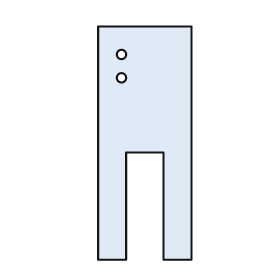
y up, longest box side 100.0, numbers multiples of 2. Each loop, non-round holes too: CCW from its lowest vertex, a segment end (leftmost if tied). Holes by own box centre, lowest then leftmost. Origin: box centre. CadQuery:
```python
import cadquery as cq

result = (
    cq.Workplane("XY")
    .moveTo(-20.0, -50.0)
    .lineTo(-8.0, -50.0)
    .lineTo(-8.0, -4.0)
    .lineTo(8.0, -4.0)
    .lineTo(8.0, -50.0)
    .lineTo(20.0, -50.0)
    .lineTo(20.0, 50.0)
    .lineTo(-20.0, 50.0)
    .close()
    .moveTo(-10.0, 28.0)
    .circle(2.0)
    .moveTo(-10.0, 38.0)
    .circle(2.0)
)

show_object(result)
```